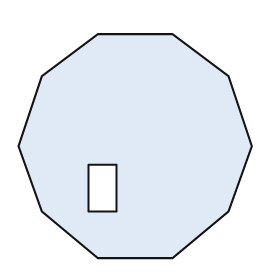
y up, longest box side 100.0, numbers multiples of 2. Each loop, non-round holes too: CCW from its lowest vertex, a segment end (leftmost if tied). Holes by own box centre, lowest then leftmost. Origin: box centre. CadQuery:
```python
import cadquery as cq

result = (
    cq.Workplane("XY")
    .moveTo(-16.0, -48.0)
    .lineTo(16.0, -48.0)
    .lineTo(40.0, -28.0)
    .lineTo(50.0, 0.0)
    .lineTo(40.0, 30.0)
    .lineTo(16.0, 48.0)
    .lineTo(-16.0, 48.0)
    .lineTo(-40.0, 30.0)
    .lineTo(-50.0, 0.0)
    .lineTo(-40.0, -28.0)
    .close()
    .moveTo(-20.0, -28.0)
    .lineTo(-8.0, -28.0)
    .lineTo(-8.0, -8.0)
    .lineTo(-20.0, -8.0)
    .close()
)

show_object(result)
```